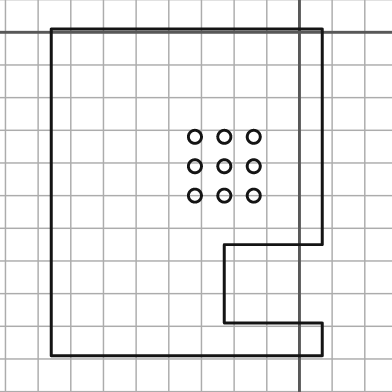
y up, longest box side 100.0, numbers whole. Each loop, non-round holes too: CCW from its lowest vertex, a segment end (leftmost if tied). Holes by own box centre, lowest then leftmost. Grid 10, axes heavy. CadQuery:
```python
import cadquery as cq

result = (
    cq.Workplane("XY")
    .moveTo(-76.0, -99.0)
    .lineTo(7.0, -99.0)
    .lineTo(7.0, -89.0)
    .lineTo(-23.0, -89.0)
    .lineTo(-23.0, -65.0)
    .lineTo(7.0, -65.0)
    .lineTo(7.0, 1.0)
    .lineTo(-76.0, 1.0)
    .close()
    .moveTo(-32.0, -50.0)
    .circle(2.0)
    .moveTo(-23.0, -50.0)
    .circle(2.0)
    .moveTo(-14.0, -50.0)
    .circle(2.0)
    .moveTo(-32.0, -41.0)
    .circle(2.0)
    .moveTo(-23.0, -41.0)
    .circle(2.0)
    .moveTo(-14.0, -41.0)
    .circle(2.0)
    .moveTo(-32.0, -32.0)
    .circle(2.0)
    .moveTo(-23.0, -32.0)
    .circle(2.0)
    .moveTo(-14.0, -32.0)
    .circle(2.0)
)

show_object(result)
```